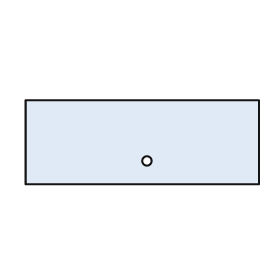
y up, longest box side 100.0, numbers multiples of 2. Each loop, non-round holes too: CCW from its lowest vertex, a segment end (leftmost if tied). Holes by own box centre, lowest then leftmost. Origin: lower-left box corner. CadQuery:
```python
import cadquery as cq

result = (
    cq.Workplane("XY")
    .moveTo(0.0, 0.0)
    .lineTo(100.0, 0.0)
    .lineTo(100.0, 36.0)
    .lineTo(0.0, 36.0)
    .close()
    .moveTo(52.0, 10.0)
    .circle(2.0)
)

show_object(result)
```